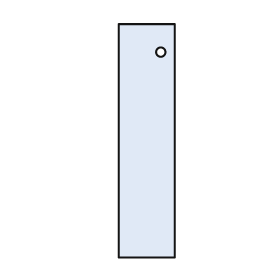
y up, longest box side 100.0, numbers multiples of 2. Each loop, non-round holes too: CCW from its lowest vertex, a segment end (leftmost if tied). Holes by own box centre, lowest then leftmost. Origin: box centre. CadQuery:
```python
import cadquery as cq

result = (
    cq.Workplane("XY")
    .moveTo(-12.0, -50.0)
    .lineTo(12.0, -50.0)
    .lineTo(12.0, 50.0)
    .lineTo(-12.0, 50.0)
    .close()
    .moveTo(6.0, 38.0)
    .circle(2.0)
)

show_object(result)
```